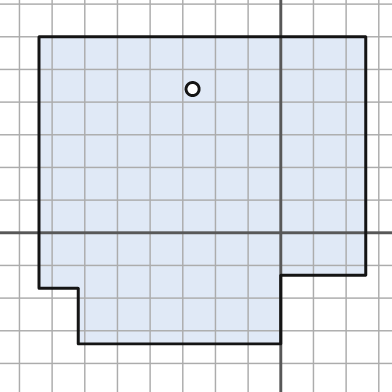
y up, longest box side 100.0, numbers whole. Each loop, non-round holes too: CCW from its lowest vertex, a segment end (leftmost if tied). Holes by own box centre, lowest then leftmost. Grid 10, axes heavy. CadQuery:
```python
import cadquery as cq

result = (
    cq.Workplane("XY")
    .moveTo(-62.0, -34.0)
    .lineTo(0.0, -34.0)
    .lineTo(0.0, -13.0)
    .lineTo(26.0, -13.0)
    .lineTo(26.0, 60.0)
    .lineTo(-74.0, 60.0)
    .lineTo(-74.0, -17.0)
    .lineTo(-62.0, -17.0)
    .close()
    .moveTo(-27.0, 44.0)
    .circle(2.0)
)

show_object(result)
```